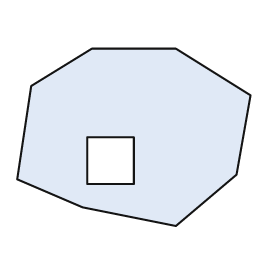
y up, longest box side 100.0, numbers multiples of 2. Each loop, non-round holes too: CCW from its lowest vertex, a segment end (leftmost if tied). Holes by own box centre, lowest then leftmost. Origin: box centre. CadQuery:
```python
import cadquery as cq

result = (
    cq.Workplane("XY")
    .moveTo(18.0, -38.0)
    .lineTo(44.0, -16.0)
    .lineTo(50.0, 18.0)
    .lineTo(18.0, 38.0)
    .lineTo(-18.0, 38.0)
    .lineTo(-44.0, 22.0)
    .lineTo(-50.0, -18.0)
    .lineTo(-22.0, -30.0)
    .close()
    .moveTo(-20.0, -20.0)
    .lineTo(0.0, -20.0)
    .lineTo(0.0, 0.0)
    .lineTo(-20.0, 0.0)
    .close()
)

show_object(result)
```